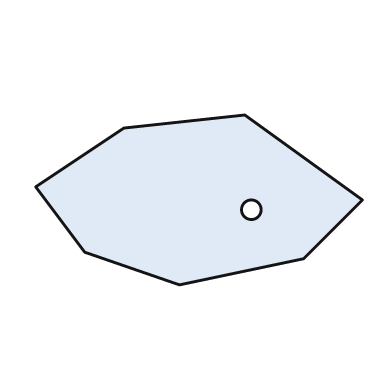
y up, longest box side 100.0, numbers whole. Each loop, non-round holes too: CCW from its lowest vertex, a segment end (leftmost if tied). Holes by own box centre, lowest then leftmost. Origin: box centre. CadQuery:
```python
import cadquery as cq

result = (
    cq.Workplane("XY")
    .moveTo(-6.0, -26.0)
    .lineTo(32.0, -18.0)
    .lineTo(50.0, 0.0)
    .lineTo(14.0, 26.0)
    .lineTo(-23.0, 22.0)
    .lineTo(-50.0, 4.0)
    .lineTo(-35.0, -16.0)
    .close()
    .moveTo(16.0, -3.0)
    .circle(3.0)
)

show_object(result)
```